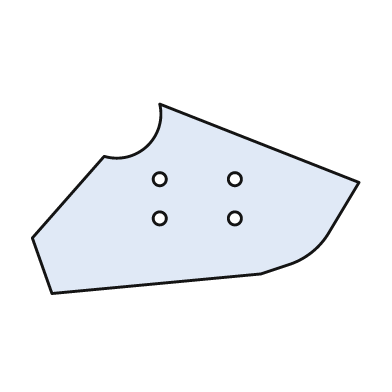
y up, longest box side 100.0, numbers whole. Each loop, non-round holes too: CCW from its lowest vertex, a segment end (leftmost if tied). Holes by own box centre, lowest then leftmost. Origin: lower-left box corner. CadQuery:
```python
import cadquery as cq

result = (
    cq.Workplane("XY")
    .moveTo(6.0, 0.0)
    .lineTo(70.0, 6.0)
    .lineTo(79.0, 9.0)
    .threePointArc((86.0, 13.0), (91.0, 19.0))
    .lineTo(100.0, 34.0)
    .lineTo(39.0, 58.0)
    .threePointArc((35.0, 45.0), (22.0, 42.0))
    .lineTo(0.0, 17.0)
    .close()
    .moveTo(39.0, 23.0)
    .circle(2.0)
    .moveTo(62.0, 23.0)
    .circle(2.0)
    .moveTo(39.0, 35.0)
    .circle(2.0)
    .moveTo(62.0, 35.0)
    .circle(2.0)
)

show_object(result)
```